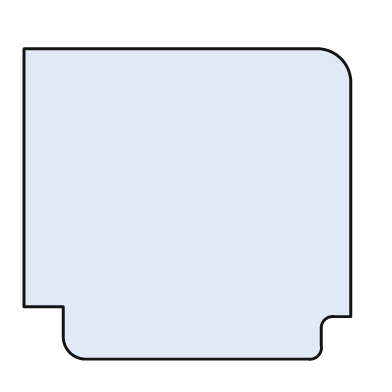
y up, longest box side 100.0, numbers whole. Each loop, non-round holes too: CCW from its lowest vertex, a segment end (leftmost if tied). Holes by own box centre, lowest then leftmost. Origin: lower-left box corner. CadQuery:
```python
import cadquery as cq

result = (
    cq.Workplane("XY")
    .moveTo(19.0, 0.0)
    .lineTo(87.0, 0.0)
    .threePointArc((90.0, 1.0), (91.0, 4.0))
    .lineTo(91.0, 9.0)
    .threePointArc((92.0, 12.0), (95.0, 13.0))
    .lineTo(100.0, 13.0)
    .lineTo(100.0, 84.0)
    .threePointArc((97.0, 92.0), (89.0, 95.0))
    .lineTo(0.0, 95.0)
    .lineTo(0.0, 16.0)
    .lineTo(12.0, 16.0)
    .lineTo(12.0, 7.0)
    .threePointArc((14.0, 2.0), (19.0, 0.0))
    .close()
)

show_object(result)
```